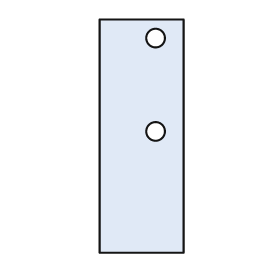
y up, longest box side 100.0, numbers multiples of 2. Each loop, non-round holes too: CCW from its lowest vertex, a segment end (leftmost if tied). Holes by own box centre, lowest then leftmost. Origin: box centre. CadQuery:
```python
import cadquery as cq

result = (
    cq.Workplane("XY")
    .moveTo(-18.0, -50.0)
    .lineTo(18.0, -50.0)
    .lineTo(18.0, 50.0)
    .lineTo(-18.0, 50.0)
    .close()
    .moveTo(6.0, 2.0)
    .circle(4.0)
    .moveTo(6.0, 42.0)
    .circle(4.0)
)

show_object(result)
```